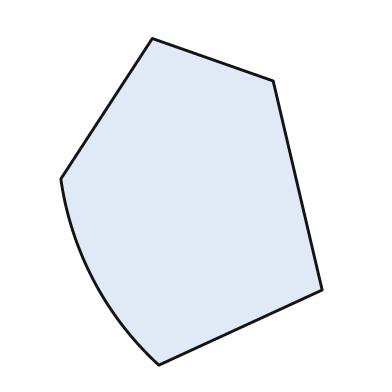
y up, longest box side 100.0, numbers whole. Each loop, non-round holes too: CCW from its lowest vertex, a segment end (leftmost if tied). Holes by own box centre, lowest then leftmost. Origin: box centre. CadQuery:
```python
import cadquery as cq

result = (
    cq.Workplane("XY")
    .moveTo(-10.0, -50.0)
    .lineTo(40.0, -27.0)
    .lineTo(25.0, 37.0)
    .lineTo(-12.0, 50.0)
    .lineTo(-40.0, 7.0)
    .threePointArc((-30.0, -24.0), (-10.0, -50.0))
    .close()
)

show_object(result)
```